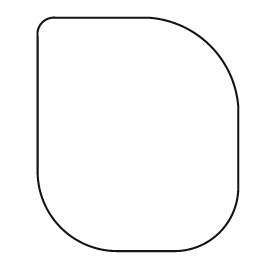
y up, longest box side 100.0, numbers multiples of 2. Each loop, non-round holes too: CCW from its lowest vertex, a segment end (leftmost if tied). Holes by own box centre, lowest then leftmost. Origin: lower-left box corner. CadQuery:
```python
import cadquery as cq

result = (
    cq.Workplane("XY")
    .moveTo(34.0, 0.0)
    .lineTo(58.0, 0.0)
    .threePointArc((78.0, 8.0), (86.0, 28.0))
    .lineTo(86.0, 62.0)
    .threePointArc((74.0, 88.0), (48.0, 100.0))
    .lineTo(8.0, 100.0)
    .threePointArc((2.0, 98.0), (0.0, 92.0))
    .lineTo(0.0, 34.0)
    .threePointArc((10.0, 10.0), (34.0, 0.0))
    .close()
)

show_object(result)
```